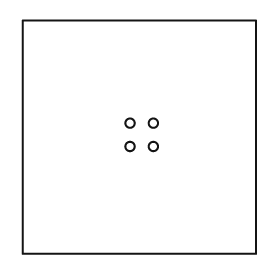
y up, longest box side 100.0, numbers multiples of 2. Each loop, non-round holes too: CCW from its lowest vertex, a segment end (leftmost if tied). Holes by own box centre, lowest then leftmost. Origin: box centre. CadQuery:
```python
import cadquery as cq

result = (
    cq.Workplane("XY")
    .moveTo(-50.0, -50.0)
    .lineTo(50.0, -50.0)
    .lineTo(50.0, 50.0)
    .lineTo(-50.0, 50.0)
    .close()
    .moveTo(-4.0, -4.0)
    .circle(2.0)
    .moveTo(6.0, -4.0)
    .circle(2.0)
    .moveTo(-4.0, 6.0)
    .circle(2.0)
    .moveTo(6.0, 6.0)
    .circle(2.0)
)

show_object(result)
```